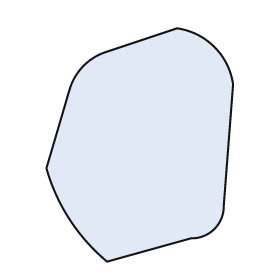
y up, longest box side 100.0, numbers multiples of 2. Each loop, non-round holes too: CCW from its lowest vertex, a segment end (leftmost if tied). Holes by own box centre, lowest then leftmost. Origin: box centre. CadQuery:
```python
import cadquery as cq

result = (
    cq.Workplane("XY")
    .moveTo(-14.0, -50.0)
    .lineTo(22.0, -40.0)
    .threePointArc((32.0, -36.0), (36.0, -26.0))
    .lineTo(40.0, 26.0)
    .threePointArc((32.0, 42.0), (16.0, 50.0))
    .lineTo(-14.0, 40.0)
    .threePointArc((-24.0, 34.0), (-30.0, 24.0))
    .lineTo(-40.0, -10.0)
    .threePointArc((-30.0, -32.0), (-14.0, -50.0))
    .close()
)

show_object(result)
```